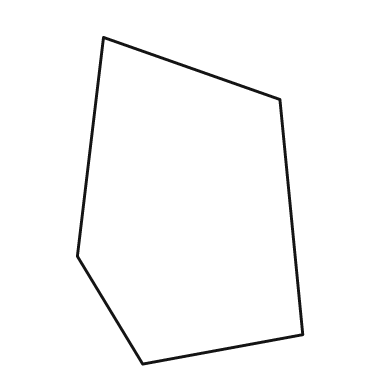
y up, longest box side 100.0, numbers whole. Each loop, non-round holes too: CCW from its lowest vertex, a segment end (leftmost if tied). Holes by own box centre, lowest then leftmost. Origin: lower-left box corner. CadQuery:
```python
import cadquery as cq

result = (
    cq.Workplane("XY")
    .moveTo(20.0, 0.0)
    .lineTo(69.0, 9.0)
    .lineTo(62.0, 81.0)
    .lineTo(8.0, 100.0)
    .lineTo(0.0, 33.0)
    .close()
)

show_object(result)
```